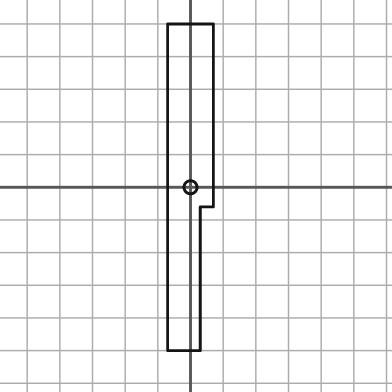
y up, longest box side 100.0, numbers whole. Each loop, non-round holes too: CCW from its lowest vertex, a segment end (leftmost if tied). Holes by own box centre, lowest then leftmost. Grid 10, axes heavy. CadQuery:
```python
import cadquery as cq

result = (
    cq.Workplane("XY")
    .moveTo(-7.0, -50.0)
    .lineTo(3.0, -50.0)
    .lineTo(3.0, -6.0)
    .lineTo(7.0, -6.0)
    .lineTo(7.0, 50.0)
    .lineTo(-7.0, 50.0)
    .close()
    .moveTo(0.0, 0.0)
    .circle(2.0)
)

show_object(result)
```